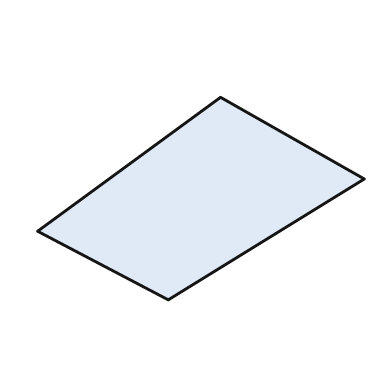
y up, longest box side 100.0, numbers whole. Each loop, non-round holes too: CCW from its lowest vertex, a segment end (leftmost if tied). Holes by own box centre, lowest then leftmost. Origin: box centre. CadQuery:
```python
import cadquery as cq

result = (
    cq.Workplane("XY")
    .moveTo(-10.0, -31.0)
    .lineTo(50.0, 6.0)
    .lineTo(6.0, 31.0)
    .lineTo(-50.0, -10.0)
    .close()
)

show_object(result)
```